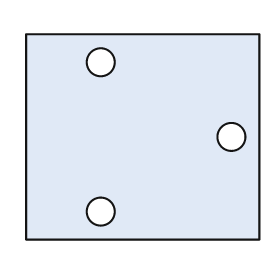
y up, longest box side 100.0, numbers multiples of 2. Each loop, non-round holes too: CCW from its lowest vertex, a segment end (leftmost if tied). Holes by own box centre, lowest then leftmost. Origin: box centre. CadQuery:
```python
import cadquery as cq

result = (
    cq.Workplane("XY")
    .moveTo(-50.0, -44.0)
    .lineTo(50.0, -44.0)
    .lineTo(50.0, 44.0)
    .lineTo(-50.0, 44.0)
    .close()
    .moveTo(-18.0, -32.0)
    .circle(6.0)
    .moveTo(38.0, 0.0)
    .circle(6.0)
    .moveTo(-18.0, 32.0)
    .circle(6.0)
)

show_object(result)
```